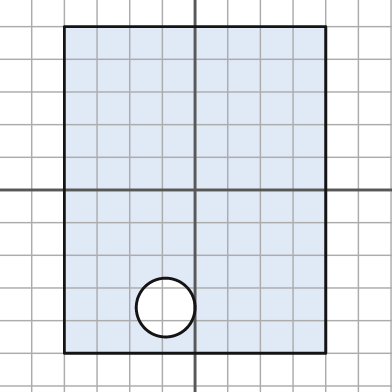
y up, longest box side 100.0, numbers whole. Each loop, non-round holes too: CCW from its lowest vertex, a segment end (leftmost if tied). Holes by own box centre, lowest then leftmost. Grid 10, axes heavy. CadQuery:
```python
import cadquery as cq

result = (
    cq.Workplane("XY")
    .moveTo(-40.0, -50.0)
    .lineTo(40.0, -50.0)
    .lineTo(40.0, 50.0)
    .lineTo(-40.0, 50.0)
    .close()
    .moveTo(-9.0, -36.0)
    .circle(9.0)
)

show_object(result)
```